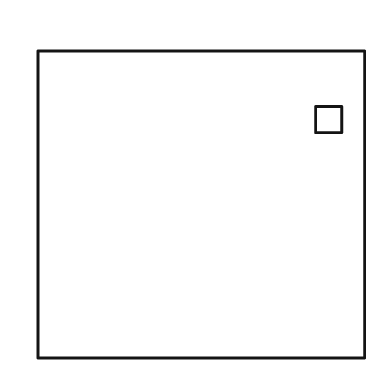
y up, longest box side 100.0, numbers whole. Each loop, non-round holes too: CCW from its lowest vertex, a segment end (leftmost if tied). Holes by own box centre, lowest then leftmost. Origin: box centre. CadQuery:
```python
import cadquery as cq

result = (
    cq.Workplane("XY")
    .moveTo(-50.0, -47.0)
    .lineTo(50.0, -47.0)
    .lineTo(50.0, 47.0)
    .lineTo(-50.0, 47.0)
    .close()
    .moveTo(35.0, 22.0)
    .lineTo(43.0, 22.0)
    .lineTo(43.0, 30.0)
    .lineTo(35.0, 30.0)
    .close()
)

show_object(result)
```